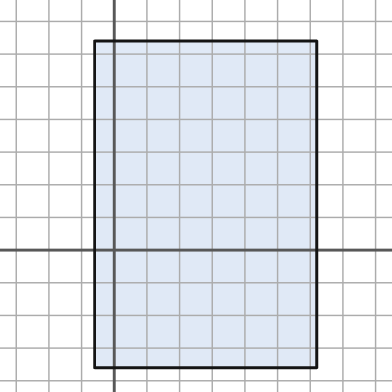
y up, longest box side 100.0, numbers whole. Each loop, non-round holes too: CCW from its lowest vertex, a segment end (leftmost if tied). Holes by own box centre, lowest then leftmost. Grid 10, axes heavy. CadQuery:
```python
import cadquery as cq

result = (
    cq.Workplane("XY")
    .moveTo(-6.0, -36.0)
    .lineTo(62.0, -36.0)
    .lineTo(62.0, 64.0)
    .lineTo(-6.0, 64.0)
    .close()
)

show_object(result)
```